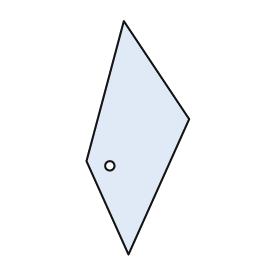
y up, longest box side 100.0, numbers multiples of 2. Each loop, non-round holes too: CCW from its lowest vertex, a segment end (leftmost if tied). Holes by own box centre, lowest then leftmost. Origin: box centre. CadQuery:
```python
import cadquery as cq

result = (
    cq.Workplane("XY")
    .moveTo(-4.0, -50.0)
    .lineTo(22.0, 8.0)
    .lineTo(-6.0, 50.0)
    .lineTo(-22.0, -10.0)
    .close()
    .moveTo(-12.0, -12.0)
    .circle(2.0)
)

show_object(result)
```